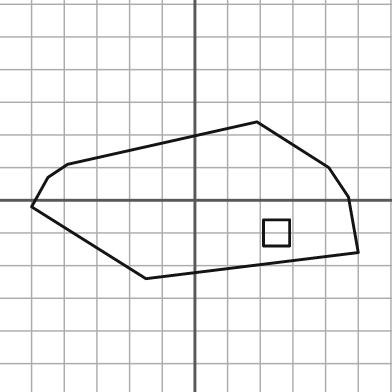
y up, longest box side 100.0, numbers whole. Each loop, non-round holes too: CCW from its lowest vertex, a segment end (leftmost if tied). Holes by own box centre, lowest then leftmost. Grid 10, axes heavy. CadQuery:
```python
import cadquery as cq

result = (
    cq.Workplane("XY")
    .moveTo(-15.0, -24.0)
    .lineTo(50.0, -16.0)
    .lineTo(47.0, 1.0)
    .lineTo(41.0, 10.0)
    .lineTo(19.0, 24.0)
    .lineTo(-39.0, 11.0)
    .lineTo(-45.0, 7.0)
    .lineTo(-50.0, -2.0)
    .close()
    .moveTo(21.0, -14.0)
    .lineTo(29.0, -14.0)
    .lineTo(29.0, -6.0)
    .lineTo(21.0, -6.0)
    .close()
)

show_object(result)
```